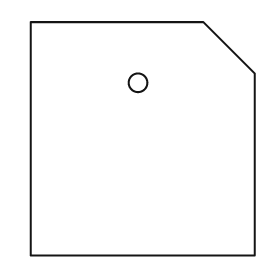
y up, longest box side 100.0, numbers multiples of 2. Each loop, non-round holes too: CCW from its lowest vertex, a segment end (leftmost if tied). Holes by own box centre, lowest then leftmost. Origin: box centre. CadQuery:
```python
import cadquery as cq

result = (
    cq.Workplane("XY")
    .moveTo(-48.0, -50.0)
    .lineTo(48.0, -50.0)
    .lineTo(48.0, 28.0)
    .lineTo(26.0, 50.0)
    .lineTo(-48.0, 50.0)
    .close()
    .moveTo(-2.0, 24.0)
    .circle(4.0)
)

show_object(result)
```